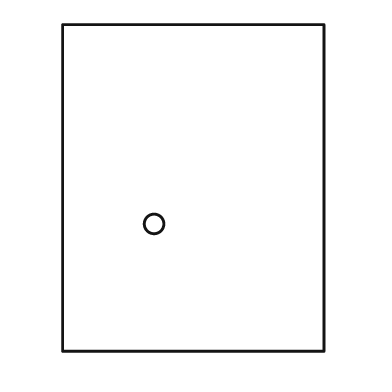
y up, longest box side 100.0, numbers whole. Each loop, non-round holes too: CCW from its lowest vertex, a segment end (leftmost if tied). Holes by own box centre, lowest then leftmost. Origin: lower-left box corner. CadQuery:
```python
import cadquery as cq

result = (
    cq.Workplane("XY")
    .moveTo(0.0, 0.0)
    .lineTo(80.0, 0.0)
    .lineTo(80.0, 100.0)
    .lineTo(0.0, 100.0)
    .close()
    .moveTo(28.0, 39.0)
    .circle(3.0)
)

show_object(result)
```